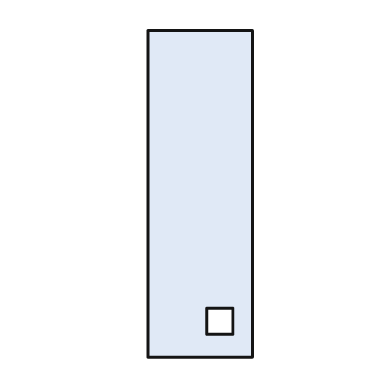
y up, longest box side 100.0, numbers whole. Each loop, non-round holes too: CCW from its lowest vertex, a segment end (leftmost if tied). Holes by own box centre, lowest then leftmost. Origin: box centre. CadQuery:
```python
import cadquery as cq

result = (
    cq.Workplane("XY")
    .moveTo(-16.0, -50.0)
    .lineTo(16.0, -50.0)
    .lineTo(16.0, 50.0)
    .lineTo(-16.0, 50.0)
    .close()
    .moveTo(2.0, -43.0)
    .lineTo(10.0, -43.0)
    .lineTo(10.0, -35.0)
    .lineTo(2.0, -35.0)
    .close()
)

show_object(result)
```